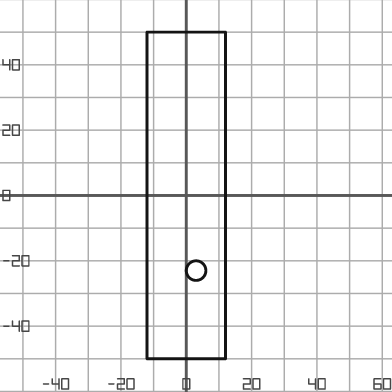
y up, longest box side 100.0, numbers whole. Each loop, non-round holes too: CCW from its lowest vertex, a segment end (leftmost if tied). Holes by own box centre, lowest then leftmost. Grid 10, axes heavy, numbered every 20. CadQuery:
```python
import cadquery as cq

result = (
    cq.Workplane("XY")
    .moveTo(-12.0, -50.0)
    .lineTo(12.0, -50.0)
    .lineTo(12.0, 50.0)
    .lineTo(-12.0, 50.0)
    .close()
    .moveTo(3.0, -23.0)
    .circle(3.0)
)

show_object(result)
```